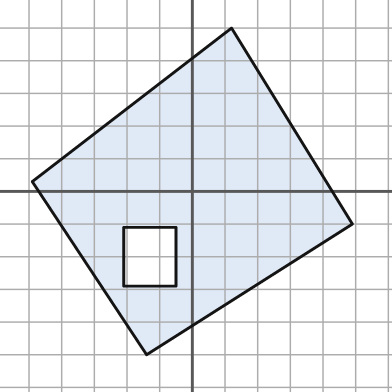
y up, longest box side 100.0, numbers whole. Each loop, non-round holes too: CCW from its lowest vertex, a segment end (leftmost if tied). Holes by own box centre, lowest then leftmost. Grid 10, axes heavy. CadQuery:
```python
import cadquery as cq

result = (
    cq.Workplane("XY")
    .moveTo(-14.0, -50.0)
    .lineTo(49.0, -10.0)
    .lineTo(12.0, 50.0)
    .lineTo(-49.0, 3.0)
    .close()
    .moveTo(-21.0, -29.0)
    .lineTo(-5.0, -29.0)
    .lineTo(-5.0, -11.0)
    .lineTo(-21.0, -11.0)
    .close()
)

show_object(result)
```